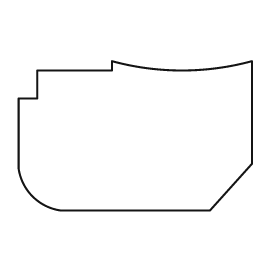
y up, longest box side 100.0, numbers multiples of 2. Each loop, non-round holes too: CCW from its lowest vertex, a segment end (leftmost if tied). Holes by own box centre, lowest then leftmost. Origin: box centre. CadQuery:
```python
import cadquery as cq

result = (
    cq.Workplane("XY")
    .moveTo(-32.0, -32.0)
    .lineTo(32.0, -32.0)
    .lineTo(50.0, -12.0)
    .lineTo(50.0, 32.0)
    .threePointArc((20.0, 28.0), (-10.0, 32.0))
    .lineTo(-10.0, 28.0)
    .lineTo(-42.0, 28.0)
    .lineTo(-42.0, 16.0)
    .lineTo(-50.0, 16.0)
    .lineTo(-50.0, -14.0)
    .threePointArc((-44.0, -26.0), (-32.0, -32.0))
    .close()
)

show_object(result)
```